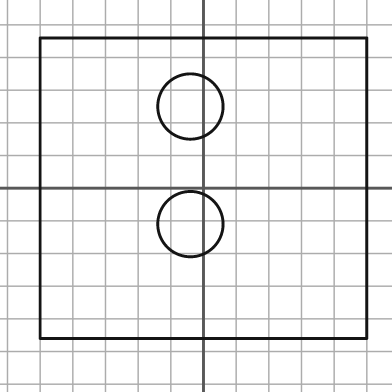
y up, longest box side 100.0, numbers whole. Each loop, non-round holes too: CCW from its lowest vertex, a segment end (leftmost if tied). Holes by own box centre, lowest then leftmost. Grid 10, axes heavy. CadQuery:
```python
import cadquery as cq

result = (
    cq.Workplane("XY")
    .moveTo(-50.0, -46.0)
    .lineTo(50.0, -46.0)
    .lineTo(50.0, 46.0)
    .lineTo(-50.0, 46.0)
    .close()
    .moveTo(-4.0, -11.0)
    .circle(10.0)
    .moveTo(-4.0, 25.0)
    .circle(10.0)
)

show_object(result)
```